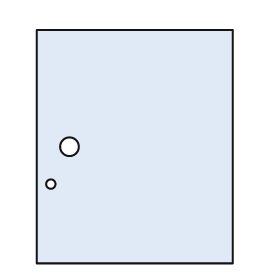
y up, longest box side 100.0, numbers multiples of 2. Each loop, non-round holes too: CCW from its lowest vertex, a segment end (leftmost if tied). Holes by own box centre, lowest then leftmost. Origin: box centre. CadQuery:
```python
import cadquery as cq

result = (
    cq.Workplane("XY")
    .moveTo(-42.0, -50.0)
    .lineTo(42.0, -50.0)
    .lineTo(42.0, 50.0)
    .lineTo(-42.0, 50.0)
    .close()
    .moveTo(-36.0, -16.0)
    .circle(2.0)
    .moveTo(-28.0, 0.0)
    .circle(4.0)
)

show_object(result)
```